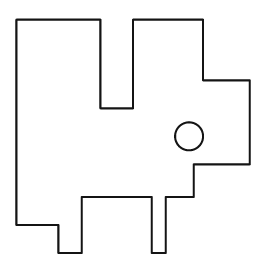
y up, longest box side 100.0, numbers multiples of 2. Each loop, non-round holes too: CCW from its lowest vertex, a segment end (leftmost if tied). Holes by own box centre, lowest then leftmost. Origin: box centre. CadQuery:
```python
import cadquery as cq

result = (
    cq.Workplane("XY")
    .moveTo(-32.0, -50.0)
    .lineTo(-22.0, -50.0)
    .lineTo(-22.0, -26.0)
    .lineTo(8.0, -26.0)
    .lineTo(8.0, -50.0)
    .lineTo(14.0, -50.0)
    .lineTo(14.0, -26.0)
    .lineTo(26.0, -26.0)
    .lineTo(26.0, -12.0)
    .lineTo(50.0, -12.0)
    .lineTo(50.0, 24.0)
    .lineTo(30.0, 24.0)
    .lineTo(30.0, 50.0)
    .lineTo(0.0, 50.0)
    .lineTo(0.0, 12.0)
    .lineTo(-14.0, 12.0)
    .lineTo(-14.0, 50.0)
    .lineTo(-50.0, 50.0)
    .lineTo(-50.0, -38.0)
    .lineTo(-32.0, -38.0)
    .close()
    .moveTo(24.0, 0.0)
    .circle(6.0)
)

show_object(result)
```